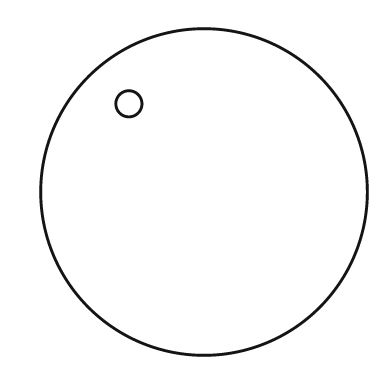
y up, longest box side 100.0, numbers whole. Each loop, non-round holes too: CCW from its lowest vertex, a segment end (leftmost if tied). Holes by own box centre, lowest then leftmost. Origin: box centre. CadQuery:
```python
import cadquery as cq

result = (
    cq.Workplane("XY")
    .moveTo(0.0, 0.0)
    .circle(50.0)
    .moveTo(-23.0, 27.0)
    .circle(4.0)
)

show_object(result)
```